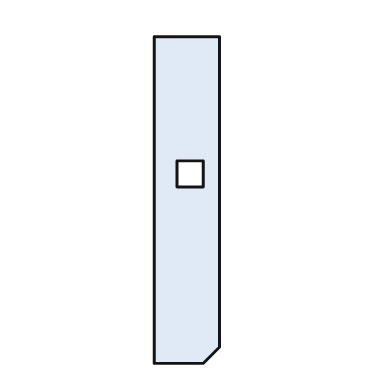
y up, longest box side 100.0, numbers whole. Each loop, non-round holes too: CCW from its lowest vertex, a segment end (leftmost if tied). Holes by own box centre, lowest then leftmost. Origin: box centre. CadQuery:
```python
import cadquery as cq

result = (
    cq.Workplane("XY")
    .moveTo(-10.0, -50.0)
    .lineTo(5.0, -50.0)
    .lineTo(10.0, -45.0)
    .lineTo(10.0, 50.0)
    .lineTo(-10.0, 50.0)
    .close()
    .moveTo(-3.0, 4.0)
    .lineTo(5.0, 4.0)
    .lineTo(5.0, 12.0)
    .lineTo(-3.0, 12.0)
    .close()
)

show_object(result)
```